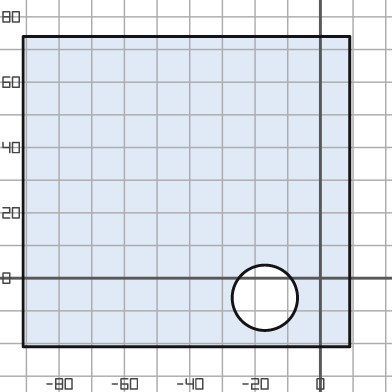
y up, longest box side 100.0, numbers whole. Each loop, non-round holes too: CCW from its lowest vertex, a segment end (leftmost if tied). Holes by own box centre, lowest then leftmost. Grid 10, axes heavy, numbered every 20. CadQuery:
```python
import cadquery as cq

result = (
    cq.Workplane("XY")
    .moveTo(-91.0, -21.0)
    .lineTo(9.0, -21.0)
    .lineTo(9.0, 74.0)
    .lineTo(-91.0, 74.0)
    .close()
    .moveTo(-17.0, -6.0)
    .circle(10.0)
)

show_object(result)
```